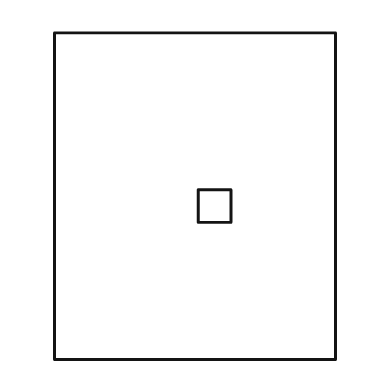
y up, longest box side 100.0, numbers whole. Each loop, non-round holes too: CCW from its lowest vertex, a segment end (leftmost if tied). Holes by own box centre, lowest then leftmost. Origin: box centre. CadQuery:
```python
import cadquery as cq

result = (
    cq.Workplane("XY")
    .moveTo(-43.0, -50.0)
    .lineTo(43.0, -50.0)
    .lineTo(43.0, 50.0)
    .lineTo(-43.0, 50.0)
    .close()
    .moveTo(1.0, -8.0)
    .lineTo(11.0, -8.0)
    .lineTo(11.0, 2.0)
    .lineTo(1.0, 2.0)
    .close()
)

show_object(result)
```